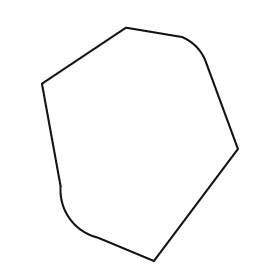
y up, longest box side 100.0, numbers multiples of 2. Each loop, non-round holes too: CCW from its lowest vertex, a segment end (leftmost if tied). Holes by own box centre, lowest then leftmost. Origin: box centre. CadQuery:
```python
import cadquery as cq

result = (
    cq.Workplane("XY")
    .moveTo(6.0, -50.0)
    .lineTo(42.0, -2.0)
    .lineTo(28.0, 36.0)
    .threePointArc((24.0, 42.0), (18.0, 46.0))
    .lineTo(-6.0, 50.0)
    .lineTo(-42.0, 26.0)
    .lineTo(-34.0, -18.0)
    .threePointArc((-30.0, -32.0), (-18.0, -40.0))
    .close()
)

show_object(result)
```